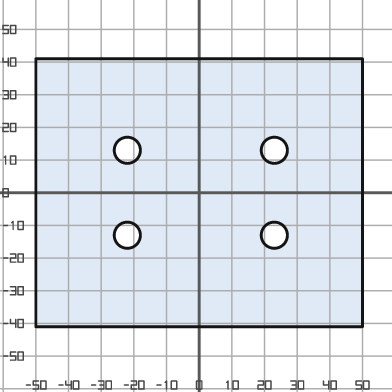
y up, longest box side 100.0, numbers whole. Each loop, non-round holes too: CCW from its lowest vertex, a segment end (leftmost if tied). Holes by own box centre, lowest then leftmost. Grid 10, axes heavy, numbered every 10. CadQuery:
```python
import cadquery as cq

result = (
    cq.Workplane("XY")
    .moveTo(-50.0, -41.0)
    .lineTo(50.0, -41.0)
    .lineTo(50.0, 41.0)
    .lineTo(-50.0, 41.0)
    .close()
    .moveTo(-22.0, -13.0)
    .circle(4.0)
    .moveTo(23.0, -13.0)
    .circle(4.0)
    .moveTo(-22.0, 13.0)
    .circle(4.0)
    .moveTo(23.0, 13.0)
    .circle(4.0)
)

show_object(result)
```